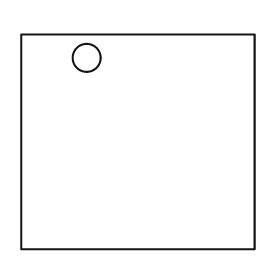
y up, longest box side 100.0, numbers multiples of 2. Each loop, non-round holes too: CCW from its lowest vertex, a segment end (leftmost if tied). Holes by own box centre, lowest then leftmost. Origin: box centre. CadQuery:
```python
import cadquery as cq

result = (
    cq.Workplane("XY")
    .moveTo(-50.0, -46.0)
    .lineTo(50.0, -46.0)
    .lineTo(50.0, 46.0)
    .lineTo(-50.0, 46.0)
    .close()
    .moveTo(-22.0, 36.0)
    .circle(6.0)
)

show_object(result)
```